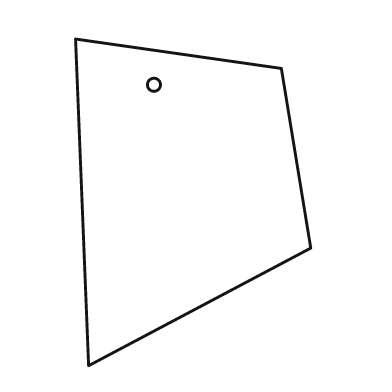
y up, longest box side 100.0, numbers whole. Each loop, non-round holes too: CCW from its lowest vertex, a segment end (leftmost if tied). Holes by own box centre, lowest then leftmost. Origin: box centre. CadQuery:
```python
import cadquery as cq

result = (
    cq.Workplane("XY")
    .moveTo(-32.0, -50.0)
    .lineTo(36.0, -14.0)
    .lineTo(27.0, 41.0)
    .lineTo(-36.0, 50.0)
    .close()
    .moveTo(-12.0, 36.0)
    .circle(2.0)
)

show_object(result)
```